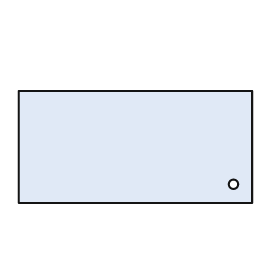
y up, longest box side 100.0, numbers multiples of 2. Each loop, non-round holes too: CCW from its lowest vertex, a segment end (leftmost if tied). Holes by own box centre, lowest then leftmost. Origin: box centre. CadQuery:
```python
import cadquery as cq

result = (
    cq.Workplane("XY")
    .moveTo(-50.0, -24.0)
    .lineTo(50.0, -24.0)
    .lineTo(50.0, 24.0)
    .lineTo(-50.0, 24.0)
    .close()
    .moveTo(42.0, -16.0)
    .circle(2.0)
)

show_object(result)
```